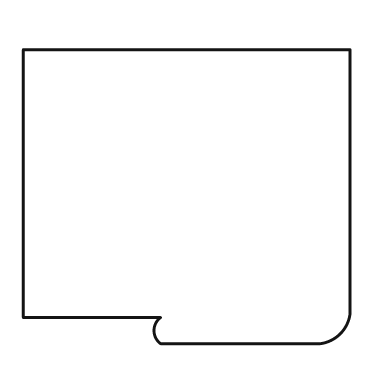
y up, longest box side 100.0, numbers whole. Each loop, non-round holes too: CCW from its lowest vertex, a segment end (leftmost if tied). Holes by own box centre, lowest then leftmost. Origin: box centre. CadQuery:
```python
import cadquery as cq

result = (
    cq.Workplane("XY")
    .moveTo(-8.0, -45.0)
    .lineTo(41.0, -45.0)
    .threePointArc((47.0, -42.0), (50.0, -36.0))
    .lineTo(50.0, 45.0)
    .lineTo(-50.0, 45.0)
    .lineTo(-50.0, -37.0)
    .lineTo(-8.0, -37.0)
    .threePointArc((-10.0, -41.0), (-8.0, -45.0))
    .close()
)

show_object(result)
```